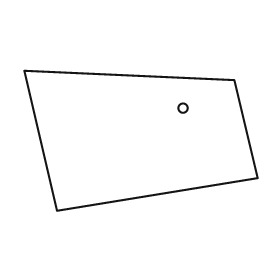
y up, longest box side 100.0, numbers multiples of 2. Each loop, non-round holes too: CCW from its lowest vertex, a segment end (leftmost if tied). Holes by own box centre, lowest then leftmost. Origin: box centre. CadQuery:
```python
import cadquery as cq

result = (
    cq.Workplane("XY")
    .moveTo(-36.0, -30.0)
    .lineTo(50.0, -16.0)
    .lineTo(40.0, 26.0)
    .lineTo(-50.0, 30.0)
    .close()
    .moveTo(18.0, 14.0)
    .circle(2.0)
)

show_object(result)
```